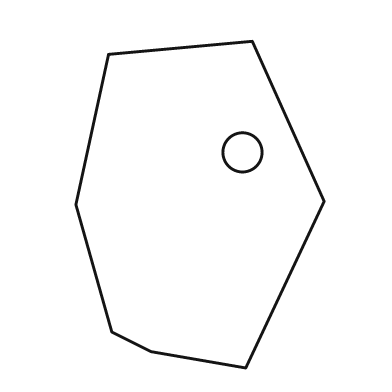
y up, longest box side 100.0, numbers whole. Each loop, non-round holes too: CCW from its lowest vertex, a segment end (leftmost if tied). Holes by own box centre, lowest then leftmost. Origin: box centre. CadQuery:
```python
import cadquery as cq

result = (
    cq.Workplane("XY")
    .moveTo(14.0, -50.0)
    .lineTo(38.0, 1.0)
    .lineTo(16.0, 50.0)
    .lineTo(-28.0, 46.0)
    .lineTo(-38.0, 0.0)
    .lineTo(-27.0, -39.0)
    .lineTo(-15.0, -45.0)
    .close()
    .moveTo(13.0, 16.0)
    .circle(6.0)
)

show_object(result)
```